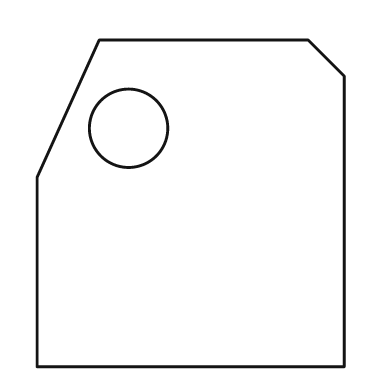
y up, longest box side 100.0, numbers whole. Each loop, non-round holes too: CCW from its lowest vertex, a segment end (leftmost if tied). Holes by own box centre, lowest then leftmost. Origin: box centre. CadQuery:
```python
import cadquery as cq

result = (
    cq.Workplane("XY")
    .moveTo(-47.0, -50.0)
    .lineTo(47.0, -50.0)
    .lineTo(47.0, 39.0)
    .lineTo(36.0, 50.0)
    .lineTo(-28.0, 50.0)
    .lineTo(-47.0, 8.0)
    .close()
    .moveTo(-19.0, 23.0)
    .circle(12.0)
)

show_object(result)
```